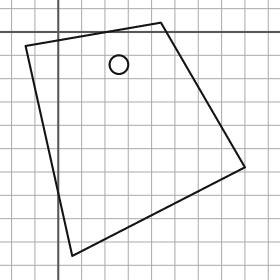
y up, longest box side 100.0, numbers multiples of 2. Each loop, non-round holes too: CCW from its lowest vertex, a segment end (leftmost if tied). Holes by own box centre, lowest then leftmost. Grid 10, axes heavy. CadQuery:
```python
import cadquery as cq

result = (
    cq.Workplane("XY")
    .moveTo(6.0, -96.0)
    .lineTo(80.0, -58.0)
    .lineTo(44.0, 4.0)
    .lineTo(-14.0, -6.0)
    .close()
    .moveTo(26.0, -14.0)
    .circle(4.0)
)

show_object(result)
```